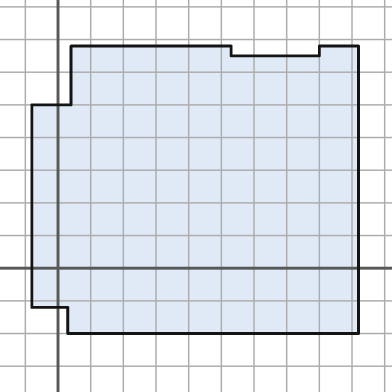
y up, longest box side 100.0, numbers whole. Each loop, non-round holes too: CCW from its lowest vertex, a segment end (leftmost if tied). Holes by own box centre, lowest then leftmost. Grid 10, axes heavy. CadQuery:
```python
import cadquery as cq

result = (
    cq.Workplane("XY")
    .moveTo(3.0, -20.0)
    .lineTo(92.0, -20.0)
    .lineTo(92.0, 68.0)
    .lineTo(80.0, 68.0)
    .lineTo(80.0, 65.0)
    .lineTo(53.0, 65.0)
    .lineTo(53.0, 68.0)
    .lineTo(4.0, 68.0)
    .lineTo(4.0, 50.0)
    .lineTo(-8.0, 50.0)
    .lineTo(-8.0, -12.0)
    .lineTo(3.0, -12.0)
    .close()
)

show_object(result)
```